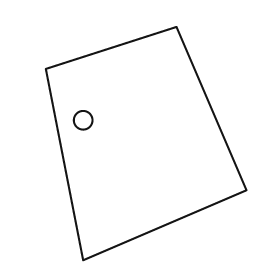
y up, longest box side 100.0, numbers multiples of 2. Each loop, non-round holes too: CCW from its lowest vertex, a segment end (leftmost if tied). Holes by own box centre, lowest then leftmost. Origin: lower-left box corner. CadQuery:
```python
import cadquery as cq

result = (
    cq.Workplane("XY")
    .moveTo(16.0, 0.0)
    .lineTo(86.0, 30.0)
    .lineTo(56.0, 100.0)
    .lineTo(0.0, 82.0)
    .close()
    .moveTo(16.0, 60.0)
    .circle(4.0)
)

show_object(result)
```